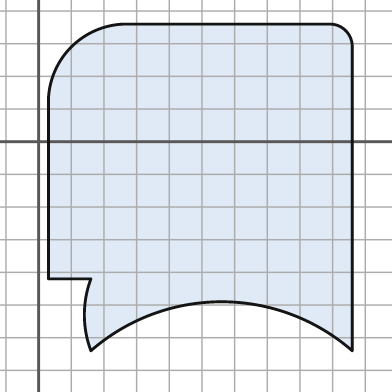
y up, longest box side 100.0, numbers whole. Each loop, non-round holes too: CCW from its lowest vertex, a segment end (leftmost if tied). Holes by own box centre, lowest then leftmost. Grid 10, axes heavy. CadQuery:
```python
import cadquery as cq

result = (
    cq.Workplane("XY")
    .moveTo(16.0, -64.0)
    .threePointArc((56.0, -49.0), (96.0, -64.0))
    .lineTo(96.0, 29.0)
    .threePointArc((94.0, 34.0), (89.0, 36.0))
    .lineTo(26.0, 36.0)
    .threePointArc((10.0, 29.0), (3.0, 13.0))
    .lineTo(3.0, -42.0)
    .lineTo(16.0, -42.0)
    .threePointArc((14.0, -53.0), (16.0, -64.0))
    .close()
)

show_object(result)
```